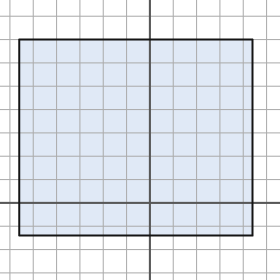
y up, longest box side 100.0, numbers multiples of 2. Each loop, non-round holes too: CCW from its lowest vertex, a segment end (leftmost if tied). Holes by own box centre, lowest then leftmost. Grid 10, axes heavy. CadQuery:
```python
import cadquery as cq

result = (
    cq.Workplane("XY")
    .moveTo(-56.0, -14.0)
    .lineTo(44.0, -14.0)
    .lineTo(44.0, 70.0)
    .lineTo(-56.0, 70.0)
    .close()
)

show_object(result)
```